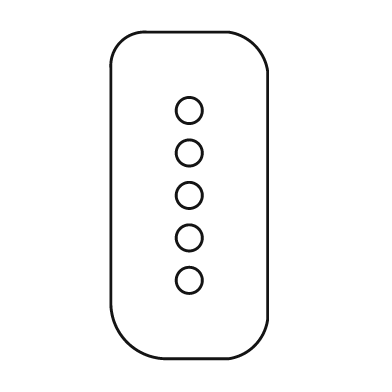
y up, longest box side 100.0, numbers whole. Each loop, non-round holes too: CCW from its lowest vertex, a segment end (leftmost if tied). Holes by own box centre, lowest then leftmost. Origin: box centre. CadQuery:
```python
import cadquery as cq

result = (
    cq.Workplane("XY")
    .moveTo(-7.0, -50.0)
    .lineTo(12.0, -50.0)
    .threePointArc((20.0, -46.0), (24.0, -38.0))
    .lineTo(24.0, 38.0)
    .threePointArc((20.0, 46.0), (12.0, 50.0))
    .lineTo(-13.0, 50.0)
    .threePointArc((-21.0, 47.0), (-24.0, 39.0))
    .lineTo(-24.0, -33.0)
    .threePointArc((-19.0, -45.0), (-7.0, -50.0))
    .close()
    .moveTo(0.0, -26.0)
    .circle(4.0)
    .moveTo(0.0, -13.0)
    .circle(4.0)
    .moveTo(0.0, 0.0)
    .circle(4.0)
    .moveTo(0.0, 13.0)
    .circle(4.0)
    .moveTo(0.0, 26.0)
    .circle(4.0)
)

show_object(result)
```